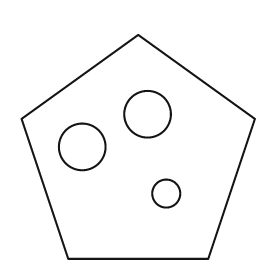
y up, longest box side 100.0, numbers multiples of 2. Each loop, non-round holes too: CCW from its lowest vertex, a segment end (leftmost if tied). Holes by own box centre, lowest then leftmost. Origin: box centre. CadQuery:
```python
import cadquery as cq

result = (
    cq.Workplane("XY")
    .moveTo(-30.0, -48.0)
    .lineTo(30.0, -48.0)
    .lineTo(50.0, 12.0)
    .lineTo(0.0, 48.0)
    .lineTo(-50.0, 12.0)
    .close()
    .moveTo(12.0, -20.0)
    .circle(6.0)
    .moveTo(-24.0, 0.0)
    .circle(10.0)
    .moveTo(4.0, 14.0)
    .circle(10.0)
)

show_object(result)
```